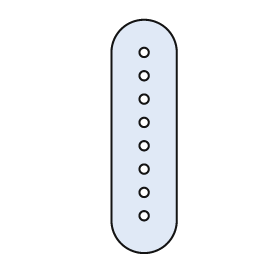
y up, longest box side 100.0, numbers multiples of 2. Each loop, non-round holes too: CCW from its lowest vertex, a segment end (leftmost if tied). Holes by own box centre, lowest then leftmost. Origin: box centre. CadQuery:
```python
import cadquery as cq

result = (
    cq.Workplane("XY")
    .moveTo(-14.0, -36.0)
    .threePointArc((0.0, -50.0), (14.0, -36.0))
    .lineTo(14.0, 36.0)
    .threePointArc((0.0, 50.0), (-14.0, 36.0))
    .close()
    .moveTo(0.0, -34.0)
    .circle(2.0)
    .moveTo(0.0, -24.0)
    .circle(2.0)
    .moveTo(0.0, -14.0)
    .circle(2.0)
    .moveTo(0.0, -4.0)
    .circle(2.0)
    .moveTo(0.0, 6.0)
    .circle(2.0)
    .moveTo(0.0, 16.0)
    .circle(2.0)
    .moveTo(0.0, 26.0)
    .circle(2.0)
    .moveTo(0.0, 36.0)
    .circle(2.0)
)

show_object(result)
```